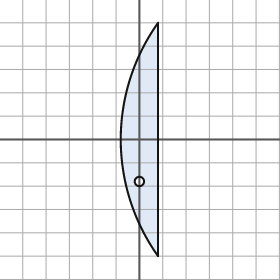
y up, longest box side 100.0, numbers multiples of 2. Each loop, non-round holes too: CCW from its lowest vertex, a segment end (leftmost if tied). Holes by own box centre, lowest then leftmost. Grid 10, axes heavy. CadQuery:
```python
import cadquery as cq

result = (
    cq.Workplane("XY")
    .moveTo(8.0, -50.0)
    .lineTo(8.0, 50.0)
    .threePointArc((-8.0, 0.0), (8.0, -50.0))
    .close()
    .moveTo(0.0, -18.0)
    .circle(2.0)
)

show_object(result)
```